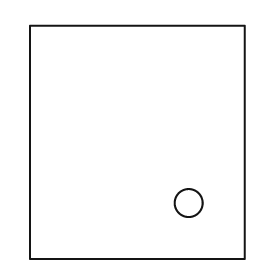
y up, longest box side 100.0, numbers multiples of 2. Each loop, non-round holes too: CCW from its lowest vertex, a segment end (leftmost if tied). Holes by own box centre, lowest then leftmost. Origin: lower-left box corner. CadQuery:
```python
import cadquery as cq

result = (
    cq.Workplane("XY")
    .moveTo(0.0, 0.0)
    .lineTo(92.0, 0.0)
    .lineTo(92.0, 100.0)
    .lineTo(0.0, 100.0)
    .close()
    .moveTo(68.0, 24.0)
    .circle(6.0)
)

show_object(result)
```